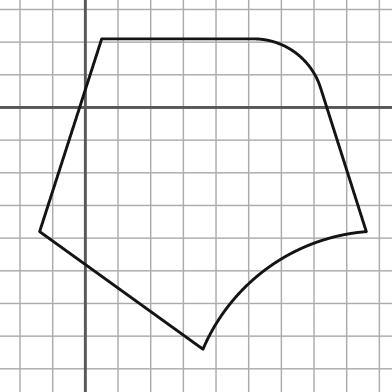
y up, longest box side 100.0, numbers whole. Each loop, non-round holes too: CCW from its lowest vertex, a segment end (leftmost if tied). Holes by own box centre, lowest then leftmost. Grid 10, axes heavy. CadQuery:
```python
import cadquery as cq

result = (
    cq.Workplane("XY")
    .moveTo(36.0, -74.0)
    .threePointArc((56.0, -49.0), (86.0, -38.0))
    .lineTo(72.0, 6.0)
    .threePointArc((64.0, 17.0), (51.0, 21.0))
    .lineTo(5.0, 21.0)
    .lineTo(-14.0, -38.0)
    .close()
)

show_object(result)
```